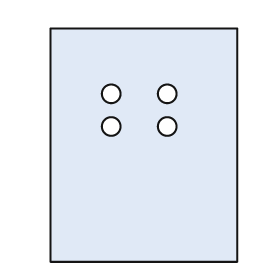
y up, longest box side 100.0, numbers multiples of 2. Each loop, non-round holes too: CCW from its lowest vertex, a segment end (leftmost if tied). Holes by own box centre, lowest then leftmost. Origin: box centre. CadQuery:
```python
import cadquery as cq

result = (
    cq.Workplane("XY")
    .moveTo(-40.0, -50.0)
    .lineTo(40.0, -50.0)
    .lineTo(40.0, 50.0)
    .lineTo(-40.0, 50.0)
    .close()
    .moveTo(-14.0, 8.0)
    .circle(4.0)
    .moveTo(10.0, 8.0)
    .circle(4.0)
    .moveTo(-14.0, 22.0)
    .circle(4.0)
    .moveTo(10.0, 22.0)
    .circle(4.0)
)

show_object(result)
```